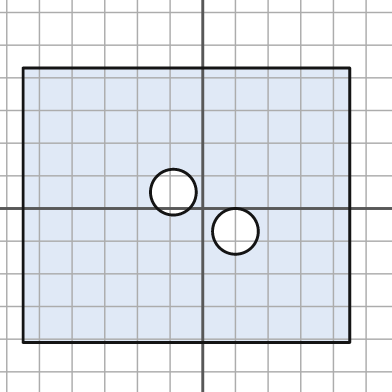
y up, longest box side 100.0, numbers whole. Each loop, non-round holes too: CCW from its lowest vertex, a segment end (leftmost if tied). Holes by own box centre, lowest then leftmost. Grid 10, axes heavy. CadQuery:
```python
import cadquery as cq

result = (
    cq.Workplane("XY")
    .moveTo(-55.0, -41.0)
    .lineTo(45.0, -41.0)
    .lineTo(45.0, 43.0)
    .lineTo(-55.0, 43.0)
    .close()
    .moveTo(10.0, -7.0)
    .circle(7.0)
    .moveTo(-9.0, 5.0)
    .circle(7.0)
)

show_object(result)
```